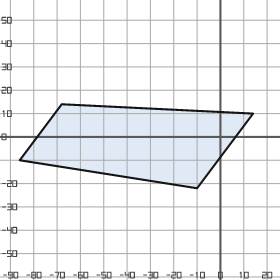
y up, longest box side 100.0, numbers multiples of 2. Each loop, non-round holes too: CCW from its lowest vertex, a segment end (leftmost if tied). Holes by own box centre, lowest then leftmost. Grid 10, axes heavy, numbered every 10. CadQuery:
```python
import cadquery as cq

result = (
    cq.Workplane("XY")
    .moveTo(-10.0, -22.0)
    .lineTo(14.0, 10.0)
    .lineTo(-68.0, 14.0)
    .lineTo(-86.0, -10.0)
    .close()
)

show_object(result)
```